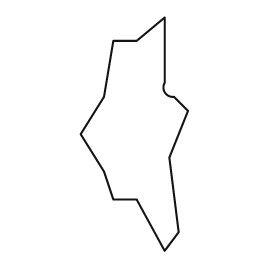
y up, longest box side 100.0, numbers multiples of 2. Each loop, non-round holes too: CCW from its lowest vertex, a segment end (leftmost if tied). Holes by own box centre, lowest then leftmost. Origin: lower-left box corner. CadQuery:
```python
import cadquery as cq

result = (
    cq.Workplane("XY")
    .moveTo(36.0, 0.0)
    .lineTo(42.0, 8.0)
    .lineTo(38.0, 40.0)
    .lineTo(46.0, 60.0)
    .lineTo(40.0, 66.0)
    .threePointArc((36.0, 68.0), (36.0, 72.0))
    .lineTo(36.0, 100.0)
    .lineTo(24.0, 90.0)
    .lineTo(14.0, 90.0)
    .lineTo(10.0, 66.0)
    .lineTo(0.0, 50.0)
    .lineTo(10.0, 34.0)
    .lineTo(14.0, 22.0)
    .lineTo(24.0, 22.0)
    .close()
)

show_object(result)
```